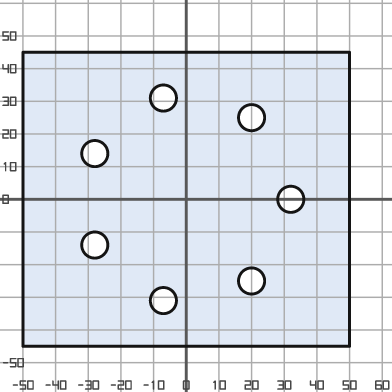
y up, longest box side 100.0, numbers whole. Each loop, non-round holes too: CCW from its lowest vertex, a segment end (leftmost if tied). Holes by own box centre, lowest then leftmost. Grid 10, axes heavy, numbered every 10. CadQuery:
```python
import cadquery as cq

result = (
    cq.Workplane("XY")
    .moveTo(-50.0, -45.0)
    .lineTo(50.0, -45.0)
    .lineTo(50.0, 45.0)
    .lineTo(-50.0, 45.0)
    .close()
    .moveTo(-7.0, -31.0)
    .circle(4.0)
    .moveTo(20.0, -25.0)
    .circle(4.0)
    .moveTo(-28.0, -14.0)
    .circle(4.0)
    .moveTo(32.0, 0.0)
    .circle(4.0)
    .moveTo(-28.0, 14.0)
    .circle(4.0)
    .moveTo(20.0, 25.0)
    .circle(4.0)
    .moveTo(-7.0, 31.0)
    .circle(4.0)
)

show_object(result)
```